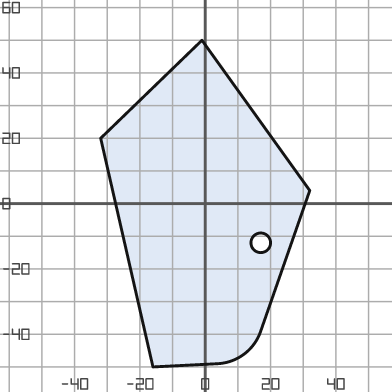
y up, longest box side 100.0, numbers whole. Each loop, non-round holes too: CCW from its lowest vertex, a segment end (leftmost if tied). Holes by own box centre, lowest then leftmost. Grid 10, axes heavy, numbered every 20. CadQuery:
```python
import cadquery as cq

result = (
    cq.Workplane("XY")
    .moveTo(-16.0, -50.0)
    .lineTo(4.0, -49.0)
    .threePointArc((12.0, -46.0), (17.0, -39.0))
    .lineTo(32.0, 4.0)
    .lineTo(-1.0, 50.0)
    .lineTo(-32.0, 20.0)
    .close()
    .moveTo(17.0, -12.0)
    .circle(3.0)
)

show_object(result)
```